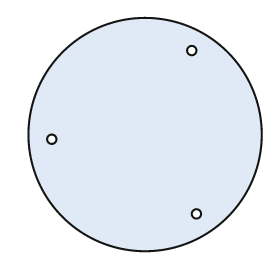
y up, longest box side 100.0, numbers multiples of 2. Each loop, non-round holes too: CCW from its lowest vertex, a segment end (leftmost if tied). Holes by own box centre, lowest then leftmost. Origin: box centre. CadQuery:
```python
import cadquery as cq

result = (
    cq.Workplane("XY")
    .moveTo(0.0, 0.0)
    .circle(50.0)
    .moveTo(22.0, -34.0)
    .circle(2.0)
    .moveTo(-40.0, -2.0)
    .circle(2.0)
    .moveTo(20.0, 36.0)
    .circle(2.0)
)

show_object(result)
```